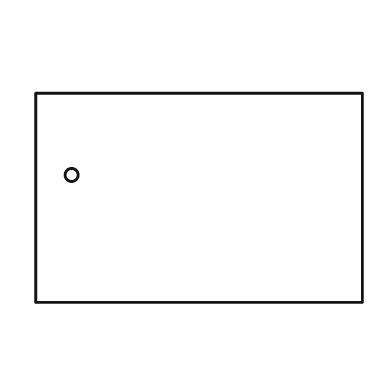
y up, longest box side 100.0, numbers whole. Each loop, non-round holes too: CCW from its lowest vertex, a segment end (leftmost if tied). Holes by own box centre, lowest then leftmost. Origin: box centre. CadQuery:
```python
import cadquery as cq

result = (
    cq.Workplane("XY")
    .moveTo(-50.0, -32.0)
    .lineTo(50.0, -32.0)
    .lineTo(50.0, 32.0)
    .lineTo(-50.0, 32.0)
    .close()
    .moveTo(-39.0, 7.0)
    .circle(2.0)
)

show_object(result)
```